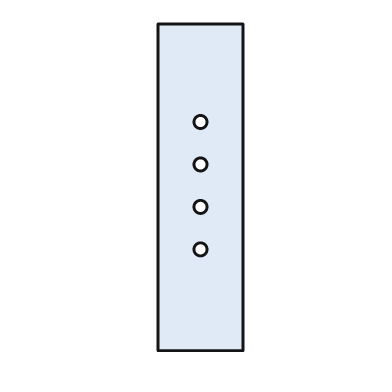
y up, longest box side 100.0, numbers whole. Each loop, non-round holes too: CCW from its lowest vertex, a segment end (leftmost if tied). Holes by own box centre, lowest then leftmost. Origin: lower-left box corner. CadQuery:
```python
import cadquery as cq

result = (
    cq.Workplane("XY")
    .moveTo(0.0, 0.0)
    .lineTo(26.0, 0.0)
    .lineTo(26.0, 100.0)
    .lineTo(0.0, 100.0)
    .close()
    .moveTo(13.0, 31.0)
    .circle(2.0)
    .moveTo(13.0, 44.0)
    .circle(2.0)
    .moveTo(13.0, 57.0)
    .circle(2.0)
    .moveTo(13.0, 70.0)
    .circle(2.0)
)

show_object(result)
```